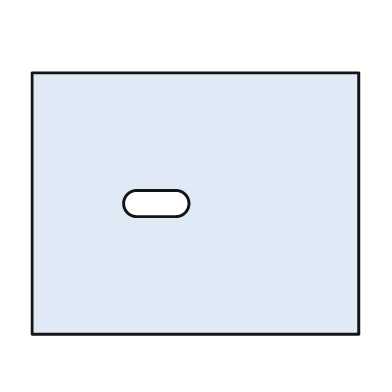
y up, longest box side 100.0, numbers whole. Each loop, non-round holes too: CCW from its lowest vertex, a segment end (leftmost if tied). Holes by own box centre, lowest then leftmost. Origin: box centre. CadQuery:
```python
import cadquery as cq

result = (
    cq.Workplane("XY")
    .moveTo(-50.0, -40.0)
    .lineTo(50.0, -40.0)
    .lineTo(50.0, 40.0)
    .lineTo(-50.0, 40.0)
    .close()
    .moveTo(-18.0, -4.0)
    .lineTo(-6.0, -4.0)
    .threePointArc((-2.0, 0.0), (-6.0, 4.0))
    .lineTo(-18.0, 4.0)
    .threePointArc((-22.0, 0.0), (-18.0, -4.0))
    .close()
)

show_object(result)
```